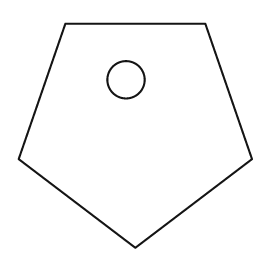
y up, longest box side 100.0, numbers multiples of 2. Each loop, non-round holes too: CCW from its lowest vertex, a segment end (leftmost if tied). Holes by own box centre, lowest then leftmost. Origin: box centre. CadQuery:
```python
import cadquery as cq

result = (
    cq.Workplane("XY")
    .moveTo(0.0, -48.0)
    .lineTo(50.0, -10.0)
    .lineTo(30.0, 48.0)
    .lineTo(-30.0, 48.0)
    .lineTo(-50.0, -10.0)
    .close()
    .moveTo(-4.0, 24.0)
    .circle(8.0)
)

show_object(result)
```